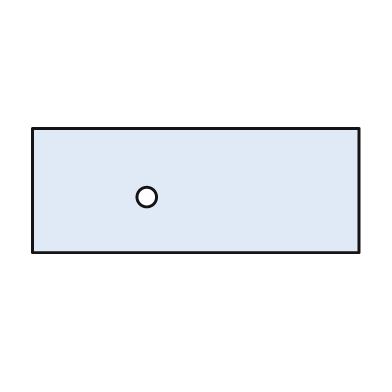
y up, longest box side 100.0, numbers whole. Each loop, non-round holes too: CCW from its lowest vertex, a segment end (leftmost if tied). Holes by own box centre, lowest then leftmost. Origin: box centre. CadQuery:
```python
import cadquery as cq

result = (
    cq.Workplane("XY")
    .moveTo(-50.0, -19.0)
    .lineTo(50.0, -19.0)
    .lineTo(50.0, 19.0)
    .lineTo(-50.0, 19.0)
    .close()
    .moveTo(-15.0, -2.0)
    .circle(3.0)
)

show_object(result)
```